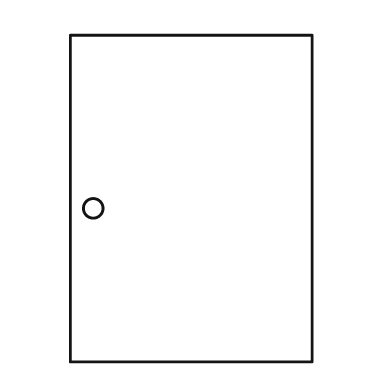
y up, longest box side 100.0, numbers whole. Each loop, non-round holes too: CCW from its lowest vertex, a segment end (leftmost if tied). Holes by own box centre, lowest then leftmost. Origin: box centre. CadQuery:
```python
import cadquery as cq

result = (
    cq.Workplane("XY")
    .moveTo(-37.0, -50.0)
    .lineTo(37.0, -50.0)
    .lineTo(37.0, 50.0)
    .lineTo(-37.0, 50.0)
    .close()
    .moveTo(-30.0, -3.0)
    .circle(3.0)
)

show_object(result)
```